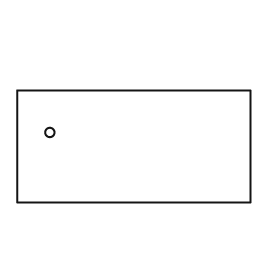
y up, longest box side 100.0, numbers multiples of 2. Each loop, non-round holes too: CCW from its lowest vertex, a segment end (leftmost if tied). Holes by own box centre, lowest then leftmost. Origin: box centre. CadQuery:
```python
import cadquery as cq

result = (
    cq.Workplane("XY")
    .moveTo(-50.0, -24.0)
    .lineTo(50.0, -24.0)
    .lineTo(50.0, 24.0)
    .lineTo(-50.0, 24.0)
    .close()
    .moveTo(-36.0, 6.0)
    .circle(2.0)
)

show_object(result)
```